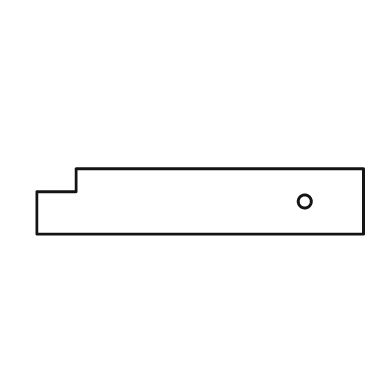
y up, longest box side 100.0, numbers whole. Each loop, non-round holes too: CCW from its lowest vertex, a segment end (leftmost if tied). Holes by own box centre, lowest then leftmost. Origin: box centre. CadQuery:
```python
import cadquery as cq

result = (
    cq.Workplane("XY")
    .moveTo(-50.0, -10.0)
    .lineTo(50.0, -10.0)
    .lineTo(50.0, 10.0)
    .lineTo(-38.0, 10.0)
    .lineTo(-38.0, 3.0)
    .lineTo(-50.0, 3.0)
    .close()
    .moveTo(32.0, 0.0)
    .circle(2.0)
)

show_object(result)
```